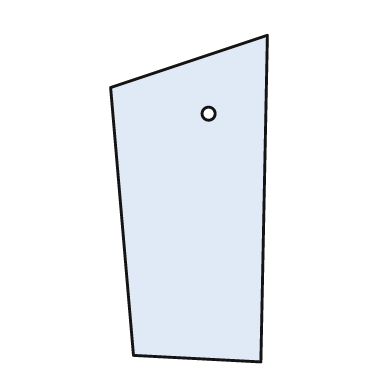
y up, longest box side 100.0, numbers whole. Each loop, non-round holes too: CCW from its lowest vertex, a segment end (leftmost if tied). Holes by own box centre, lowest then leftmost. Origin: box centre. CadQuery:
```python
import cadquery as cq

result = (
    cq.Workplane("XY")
    .moveTo(22.0, -50.0)
    .lineTo(24.0, 50.0)
    .lineTo(-24.0, 34.0)
    .lineTo(-17.0, -48.0)
    .close()
    .moveTo(6.0, 26.0)
    .circle(2.0)
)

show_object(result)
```